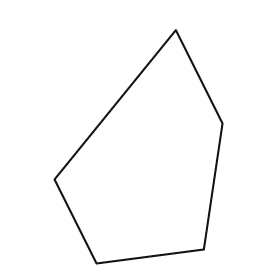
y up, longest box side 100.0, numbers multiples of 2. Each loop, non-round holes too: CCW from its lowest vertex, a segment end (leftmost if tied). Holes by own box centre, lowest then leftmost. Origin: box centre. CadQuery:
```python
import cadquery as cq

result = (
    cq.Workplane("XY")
    .moveTo(-18.0, -50.0)
    .lineTo(28.0, -44.0)
    .lineTo(36.0, 10.0)
    .lineTo(16.0, 50.0)
    .lineTo(-36.0, -14.0)
    .close()
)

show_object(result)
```